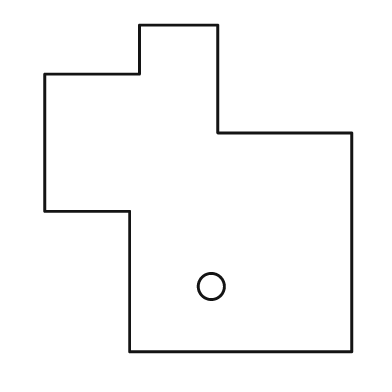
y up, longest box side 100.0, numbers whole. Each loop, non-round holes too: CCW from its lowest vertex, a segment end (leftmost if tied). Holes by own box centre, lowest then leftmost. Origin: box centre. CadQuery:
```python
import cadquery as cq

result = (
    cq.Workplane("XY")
    .moveTo(-21.0, -50.0)
    .lineTo(47.0, -50.0)
    .lineTo(47.0, 17.0)
    .lineTo(6.0, 17.0)
    .lineTo(6.0, 50.0)
    .lineTo(-18.0, 50.0)
    .lineTo(-18.0, 35.0)
    .lineTo(-47.0, 35.0)
    .lineTo(-47.0, -7.0)
    .lineTo(-21.0, -7.0)
    .close()
    .moveTo(4.0, -30.0)
    .circle(4.0)
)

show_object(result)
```